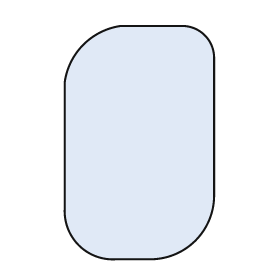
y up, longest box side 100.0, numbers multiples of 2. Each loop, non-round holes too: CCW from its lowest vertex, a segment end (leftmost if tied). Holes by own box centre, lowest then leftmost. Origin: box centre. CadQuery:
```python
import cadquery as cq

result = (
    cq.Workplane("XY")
    .moveTo(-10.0, -50.0)
    .lineTo(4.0, -50.0)
    .threePointArc((24.0, -42.0), (32.0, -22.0))
    .lineTo(32.0, 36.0)
    .threePointArc((28.0, 46.0), (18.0, 50.0))
    .lineTo(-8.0, 50.0)
    .threePointArc((-24.0, 42.0), (-32.0, 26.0))
    .lineTo(-32.0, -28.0)
    .threePointArc((-26.0, -44.0), (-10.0, -50.0))
    .close()
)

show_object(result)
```